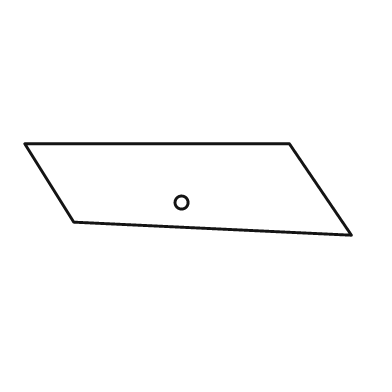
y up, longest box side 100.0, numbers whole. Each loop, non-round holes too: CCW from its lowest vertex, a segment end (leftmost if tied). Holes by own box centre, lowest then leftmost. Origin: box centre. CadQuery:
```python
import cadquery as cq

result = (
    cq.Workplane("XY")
    .moveTo(50.0, -14.0)
    .lineTo(31.0, 14.0)
    .lineTo(-50.0, 14.0)
    .lineTo(-35.0, -10.0)
    .close()
    .moveTo(-2.0, -4.0)
    .circle(2.0)
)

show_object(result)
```